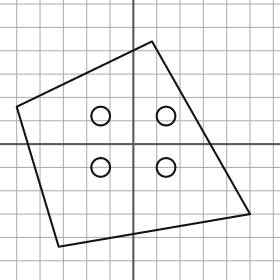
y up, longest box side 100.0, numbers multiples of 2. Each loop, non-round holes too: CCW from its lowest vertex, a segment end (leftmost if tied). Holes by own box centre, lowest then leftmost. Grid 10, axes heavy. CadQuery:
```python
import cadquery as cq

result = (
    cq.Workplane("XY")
    .moveTo(-32.0, -44.0)
    .lineTo(50.0, -30.0)
    .lineTo(8.0, 44.0)
    .lineTo(-50.0, 16.0)
    .close()
    .moveTo(-14.0, -10.0)
    .circle(4.0)
    .moveTo(14.0, -10.0)
    .circle(4.0)
    .moveTo(-14.0, 12.0)
    .circle(4.0)
    .moveTo(14.0, 12.0)
    .circle(4.0)
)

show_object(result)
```